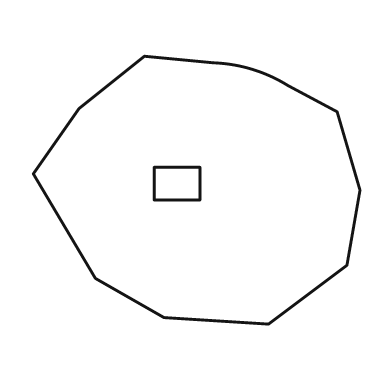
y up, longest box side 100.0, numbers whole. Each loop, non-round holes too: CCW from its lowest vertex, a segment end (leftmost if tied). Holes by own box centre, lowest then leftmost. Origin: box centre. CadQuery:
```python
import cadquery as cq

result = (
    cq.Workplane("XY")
    .moveTo(22.0, -41.0)
    .lineTo(46.0, -23.0)
    .lineTo(50.0, 0.0)
    .lineTo(43.0, 24.0)
    .lineTo(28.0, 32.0)
    .threePointArc((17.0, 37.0), (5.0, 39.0))
    .lineTo(-16.0, 41.0)
    .lineTo(-36.0, 25.0)
    .lineTo(-50.0, 5.0)
    .lineTo(-31.0, -27.0)
    .lineTo(-10.0, -39.0)
    .close()
    .moveTo(-13.0, -3.0)
    .lineTo(1.0, -3.0)
    .lineTo(1.0, 7.0)
    .lineTo(-13.0, 7.0)
    .close()
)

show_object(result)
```